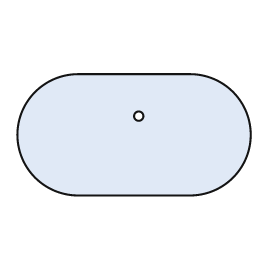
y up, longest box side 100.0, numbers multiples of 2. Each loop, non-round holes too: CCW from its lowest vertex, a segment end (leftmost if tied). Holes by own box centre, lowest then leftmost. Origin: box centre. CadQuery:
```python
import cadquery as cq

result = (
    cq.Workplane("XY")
    .moveTo(-24.0, -26.0)
    .lineTo(24.0, -26.0)
    .threePointArc((50.0, 0.0), (24.0, 26.0))
    .lineTo(-24.0, 26.0)
    .threePointArc((-50.0, 0.0), (-24.0, -26.0))
    .close()
    .moveTo(2.0, 8.0)
    .circle(2.0)
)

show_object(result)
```